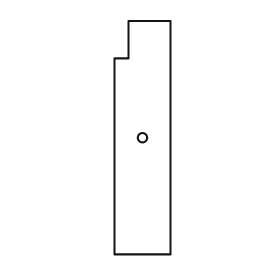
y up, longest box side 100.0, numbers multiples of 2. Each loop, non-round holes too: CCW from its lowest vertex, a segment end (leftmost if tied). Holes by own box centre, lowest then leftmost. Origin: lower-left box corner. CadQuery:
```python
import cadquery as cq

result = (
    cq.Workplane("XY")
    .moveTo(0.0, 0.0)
    .lineTo(24.0, 0.0)
    .lineTo(24.0, 100.0)
    .lineTo(6.0, 100.0)
    .lineTo(6.0, 84.0)
    .lineTo(0.0, 84.0)
    .close()
    .moveTo(12.0, 50.0)
    .circle(2.0)
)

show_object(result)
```